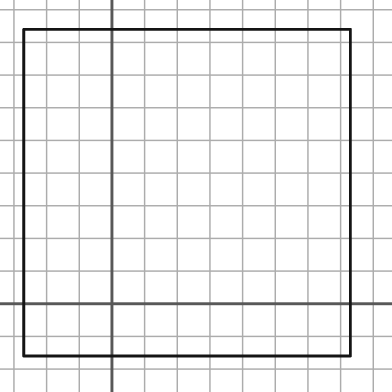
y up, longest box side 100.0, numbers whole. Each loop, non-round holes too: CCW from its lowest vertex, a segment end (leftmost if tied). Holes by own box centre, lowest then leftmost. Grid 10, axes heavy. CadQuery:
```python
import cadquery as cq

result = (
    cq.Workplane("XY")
    .moveTo(-27.0, -16.0)
    .lineTo(73.0, -16.0)
    .lineTo(73.0, 84.0)
    .lineTo(-27.0, 84.0)
    .close()
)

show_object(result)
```